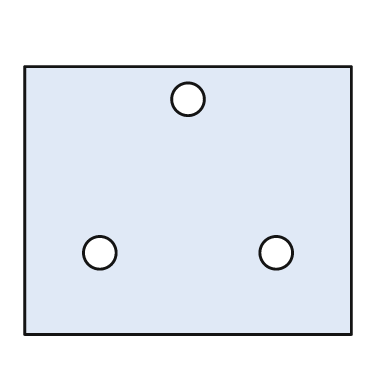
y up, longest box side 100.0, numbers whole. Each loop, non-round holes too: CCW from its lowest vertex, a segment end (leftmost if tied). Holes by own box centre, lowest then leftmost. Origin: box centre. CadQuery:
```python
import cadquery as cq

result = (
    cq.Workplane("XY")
    .moveTo(-50.0, -41.0)
    .lineTo(50.0, -41.0)
    .lineTo(50.0, 41.0)
    .lineTo(-50.0, 41.0)
    .close()
    .moveTo(-27.0, -16.0)
    .circle(5.0)
    .moveTo(27.0, -16.0)
    .circle(5.0)
    .moveTo(0.0, 31.0)
    .circle(5.0)
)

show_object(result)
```